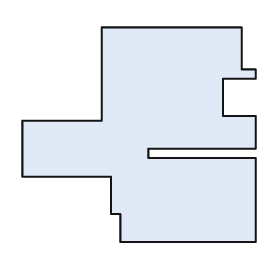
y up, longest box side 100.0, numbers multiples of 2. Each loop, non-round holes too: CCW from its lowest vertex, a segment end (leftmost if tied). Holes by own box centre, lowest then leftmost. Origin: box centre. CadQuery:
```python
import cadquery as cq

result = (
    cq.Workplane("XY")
    .moveTo(-8.0, -46.0)
    .lineTo(50.0, -46.0)
    .lineTo(50.0, -10.0)
    .lineTo(4.0, -10.0)
    .lineTo(4.0, -6.0)
    .lineTo(50.0, -6.0)
    .lineTo(50.0, 8.0)
    .lineTo(36.0, 8.0)
    .lineTo(36.0, 24.0)
    .lineTo(50.0, 24.0)
    .lineTo(50.0, 28.0)
    .lineTo(44.0, 28.0)
    .lineTo(44.0, 46.0)
    .lineTo(-16.0, 46.0)
    .lineTo(-16.0, 6.0)
    .lineTo(-50.0, 6.0)
    .lineTo(-50.0, -18.0)
    .lineTo(-12.0, -18.0)
    .lineTo(-12.0, -34.0)
    .lineTo(-8.0, -34.0)
    .close()
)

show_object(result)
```